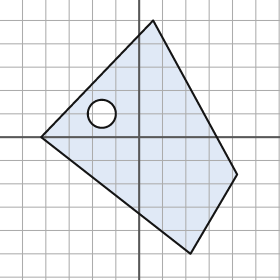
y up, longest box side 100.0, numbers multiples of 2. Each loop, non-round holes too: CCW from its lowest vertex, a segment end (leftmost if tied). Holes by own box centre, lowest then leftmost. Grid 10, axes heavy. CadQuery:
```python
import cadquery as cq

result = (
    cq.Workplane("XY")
    .moveTo(22.0, -50.0)
    .lineTo(42.0, -16.0)
    .lineTo(6.0, 50.0)
    .lineTo(-42.0, 0.0)
    .close()
    .moveTo(-16.0, 10.0)
    .circle(6.0)
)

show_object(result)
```